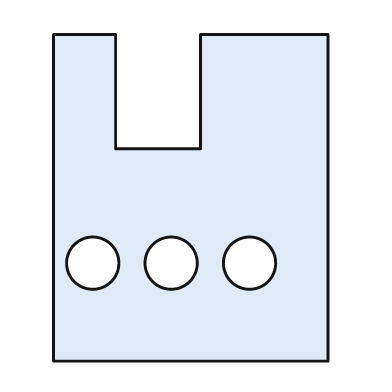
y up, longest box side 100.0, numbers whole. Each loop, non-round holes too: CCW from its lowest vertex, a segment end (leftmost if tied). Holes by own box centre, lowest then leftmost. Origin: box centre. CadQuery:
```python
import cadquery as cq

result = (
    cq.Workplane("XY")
    .moveTo(-42.0, -50.0)
    .lineTo(42.0, -50.0)
    .lineTo(42.0, 50.0)
    .lineTo(3.0, 50.0)
    .lineTo(3.0, 15.0)
    .lineTo(-23.0, 15.0)
    .lineTo(-23.0, 50.0)
    .lineTo(-42.0, 50.0)
    .close()
    .moveTo(-30.0, -20.0)
    .circle(8.0)
    .moveTo(-6.0, -20.0)
    .circle(8.0)
    .moveTo(18.0, -20.0)
    .circle(8.0)
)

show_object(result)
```